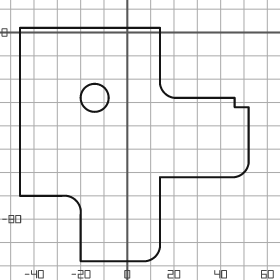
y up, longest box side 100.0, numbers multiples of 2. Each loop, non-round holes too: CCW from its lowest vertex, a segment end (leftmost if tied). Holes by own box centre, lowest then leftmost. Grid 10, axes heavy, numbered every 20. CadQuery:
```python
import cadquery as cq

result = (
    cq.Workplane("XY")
    .moveTo(-20.0, -98.0)
    .lineTo(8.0, -98.0)
    .threePointArc((12.0, -96.0), (14.0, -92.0))
    .lineTo(14.0, -62.0)
    .lineTo(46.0, -62.0)
    .threePointArc((50.0, -60.0), (52.0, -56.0))
    .lineTo(52.0, -32.0)
    .lineTo(46.0, -32.0)
    .lineTo(46.0, -28.0)
    .lineTo(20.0, -28.0)
    .threePointArc((16.0, -26.0), (14.0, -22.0))
    .lineTo(14.0, 2.0)
    .lineTo(-46.0, 2.0)
    .lineTo(-46.0, -70.0)
    .lineTo(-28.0, -70.0)
    .threePointArc((-22.0, -72.0), (-20.0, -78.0))
    .close()
    .moveTo(-14.0, -28.0)
    .circle(6.0)
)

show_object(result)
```